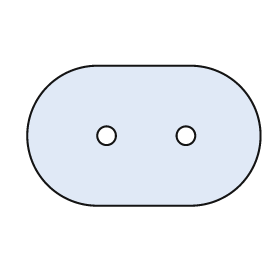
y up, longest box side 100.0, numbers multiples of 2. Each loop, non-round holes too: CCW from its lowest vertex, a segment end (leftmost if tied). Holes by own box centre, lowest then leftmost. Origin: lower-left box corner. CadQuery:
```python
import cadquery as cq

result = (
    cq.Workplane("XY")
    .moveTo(30.0, 0.0)
    .lineTo(70.0, 0.0)
    .threePointArc((100.0, 30.0), (70.0, 60.0))
    .lineTo(30.0, 60.0)
    .threePointArc((0.0, 30.0), (30.0, 0.0))
    .close()
    .moveTo(34.0, 30.0)
    .circle(4.0)
    .moveTo(68.0, 30.0)
    .circle(4.0)
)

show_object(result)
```